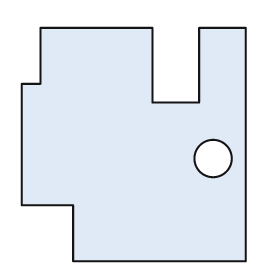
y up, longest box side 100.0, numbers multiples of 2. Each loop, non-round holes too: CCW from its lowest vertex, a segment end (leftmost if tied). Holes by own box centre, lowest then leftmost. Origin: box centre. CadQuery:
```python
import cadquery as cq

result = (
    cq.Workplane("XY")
    .moveTo(-26.0, -50.0)
    .lineTo(48.0, -50.0)
    .lineTo(48.0, 50.0)
    .lineTo(28.0, 50.0)
    .lineTo(28.0, 18.0)
    .lineTo(8.0, 18.0)
    .lineTo(8.0, 50.0)
    .lineTo(-40.0, 50.0)
    .lineTo(-40.0, 26.0)
    .lineTo(-48.0, 26.0)
    .lineTo(-48.0, -26.0)
    .lineTo(-26.0, -26.0)
    .close()
    .moveTo(34.0, -6.0)
    .circle(8.0)
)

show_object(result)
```